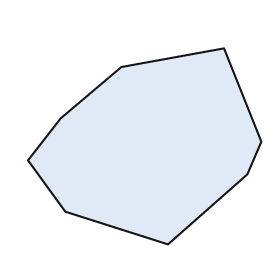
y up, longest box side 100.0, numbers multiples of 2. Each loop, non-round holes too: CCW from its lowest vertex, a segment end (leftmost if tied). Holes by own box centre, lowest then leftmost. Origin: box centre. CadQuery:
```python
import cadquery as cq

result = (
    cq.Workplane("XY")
    .moveTo(10.0, -42.0)
    .lineTo(44.0, -12.0)
    .lineTo(50.0, 2.0)
    .lineTo(34.0, 42.0)
    .lineTo(-10.0, 34.0)
    .lineTo(-36.0, 12.0)
    .lineTo(-50.0, -6.0)
    .lineTo(-34.0, -28.0)
    .close()
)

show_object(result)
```